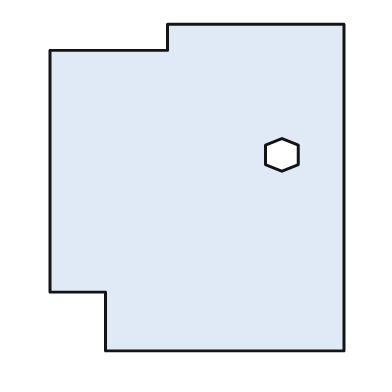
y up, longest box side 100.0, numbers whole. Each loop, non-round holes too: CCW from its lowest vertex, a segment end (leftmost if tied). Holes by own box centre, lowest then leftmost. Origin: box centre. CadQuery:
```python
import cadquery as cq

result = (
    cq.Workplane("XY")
    .moveTo(-28.0, -50.0)
    .lineTo(45.0, -50.0)
    .lineTo(45.0, 50.0)
    .lineTo(-9.0, 50.0)
    .lineTo(-9.0, 42.0)
    .lineTo(-45.0, 42.0)
    .lineTo(-45.0, -32.0)
    .lineTo(-28.0, -32.0)
    .close()
    .moveTo(26.0, 5.0)
    .lineTo(31.0, 7.0)
    .lineTo(31.0, 13.0)
    .lineTo(26.0, 15.0)
    .lineTo(21.0, 13.0)
    .lineTo(21.0, 7.0)
    .close()
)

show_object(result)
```